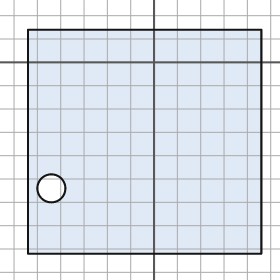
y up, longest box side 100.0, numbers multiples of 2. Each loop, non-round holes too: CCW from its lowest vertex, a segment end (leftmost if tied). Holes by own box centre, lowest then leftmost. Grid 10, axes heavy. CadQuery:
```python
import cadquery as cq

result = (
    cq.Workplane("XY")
    .moveTo(-54.0, -82.0)
    .lineTo(46.0, -82.0)
    .lineTo(46.0, 14.0)
    .lineTo(-54.0, 14.0)
    .close()
    .moveTo(-44.0, -54.0)
    .circle(6.0)
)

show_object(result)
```